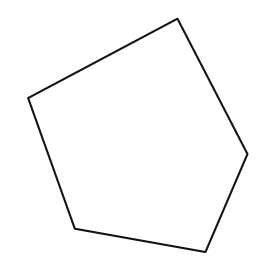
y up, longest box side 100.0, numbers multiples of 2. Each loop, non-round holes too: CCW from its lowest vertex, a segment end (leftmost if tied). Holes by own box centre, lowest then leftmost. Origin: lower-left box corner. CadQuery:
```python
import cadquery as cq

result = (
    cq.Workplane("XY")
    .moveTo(76.0, 0.0)
    .lineTo(94.0, 42.0)
    .lineTo(64.0, 100.0)
    .lineTo(0.0, 66.0)
    .lineTo(20.0, 10.0)
    .close()
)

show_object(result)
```